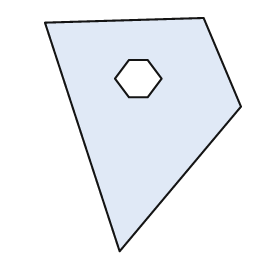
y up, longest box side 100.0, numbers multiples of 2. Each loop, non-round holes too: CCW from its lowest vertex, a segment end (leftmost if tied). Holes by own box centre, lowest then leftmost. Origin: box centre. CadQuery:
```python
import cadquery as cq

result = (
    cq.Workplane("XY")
    .moveTo(-10.0, -50.0)
    .lineTo(42.0, 12.0)
    .lineTo(26.0, 50.0)
    .lineTo(-42.0, 48.0)
    .close()
    .moveTo(-6.0, 16.0)
    .lineTo(2.0, 16.0)
    .lineTo(8.0, 24.0)
    .lineTo(2.0, 32.0)
    .lineTo(-6.0, 32.0)
    .lineTo(-12.0, 24.0)
    .close()
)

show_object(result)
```